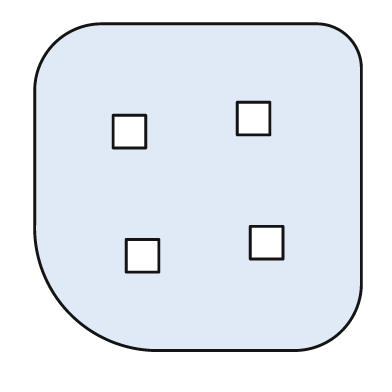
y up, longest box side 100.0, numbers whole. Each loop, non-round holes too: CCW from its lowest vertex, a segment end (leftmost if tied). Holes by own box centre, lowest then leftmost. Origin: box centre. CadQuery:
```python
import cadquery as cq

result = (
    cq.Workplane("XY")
    .moveTo(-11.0, -50.0)
    .lineTo(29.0, -50.0)
    .threePointArc((44.0, -44.0), (50.0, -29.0))
    .lineTo(50.0, 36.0)
    .threePointArc((46.0, 46.0), (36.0, 50.0))
    .lineTo(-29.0, 50.0)
    .threePointArc((-44.0, 44.0), (-50.0, 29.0))
    .lineTo(-50.0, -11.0)
    .threePointArc((-39.0, -39.0), (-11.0, -50.0))
    .close()
    .moveTo(-22.0, -26.0)
    .lineTo(-12.0, -26.0)
    .lineTo(-12.0, -16.0)
    .lineTo(-22.0, -16.0)
    .close()
    .moveTo(16.0, -22.0)
    .lineTo(26.0, -22.0)
    .lineTo(26.0, -12.0)
    .lineTo(16.0, -12.0)
    .close()
    .moveTo(-26.0, 12.0)
    .lineTo(-16.0, 12.0)
    .lineTo(-16.0, 22.0)
    .lineTo(-26.0, 22.0)
    .close()
    .moveTo(12.0, 16.0)
    .lineTo(22.0, 16.0)
    .lineTo(22.0, 26.0)
    .lineTo(12.0, 26.0)
    .close()
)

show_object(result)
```